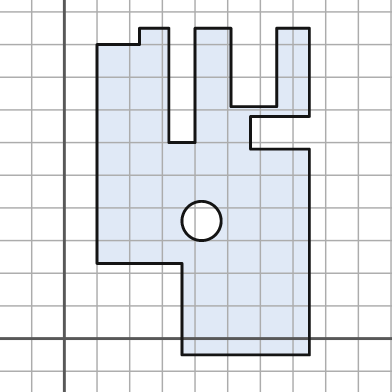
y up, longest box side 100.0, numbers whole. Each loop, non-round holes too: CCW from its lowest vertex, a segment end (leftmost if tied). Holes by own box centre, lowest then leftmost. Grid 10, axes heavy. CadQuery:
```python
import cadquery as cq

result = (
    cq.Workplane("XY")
    .moveTo(36.0, -5.0)
    .lineTo(75.0, -5.0)
    .lineTo(75.0, 58.0)
    .lineTo(57.0, 58.0)
    .lineTo(57.0, 68.0)
    .lineTo(75.0, 68.0)
    .lineTo(75.0, 95.0)
    .lineTo(65.0, 95.0)
    .lineTo(65.0, 71.0)
    .lineTo(51.0, 71.0)
    .lineTo(51.0, 95.0)
    .lineTo(40.0, 95.0)
    .lineTo(40.0, 60.0)
    .lineTo(32.0, 60.0)
    .lineTo(32.0, 95.0)
    .lineTo(23.0, 95.0)
    .lineTo(23.0, 90.0)
    .lineTo(10.0, 90.0)
    .lineTo(10.0, 23.0)
    .lineTo(36.0, 23.0)
    .close()
    .moveTo(42.0, 36.0)
    .circle(6.0)
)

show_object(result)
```